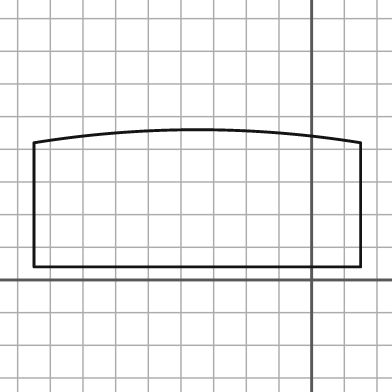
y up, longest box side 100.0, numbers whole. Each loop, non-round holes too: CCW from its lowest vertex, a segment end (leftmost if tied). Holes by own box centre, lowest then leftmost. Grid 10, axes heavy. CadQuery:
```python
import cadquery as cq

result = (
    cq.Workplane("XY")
    .moveTo(-85.0, 4.0)
    .lineTo(15.0, 4.0)
    .lineTo(15.0, 42.0)
    .threePointArc((-35.0, 46.0), (-85.0, 42.0))
    .close()
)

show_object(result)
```